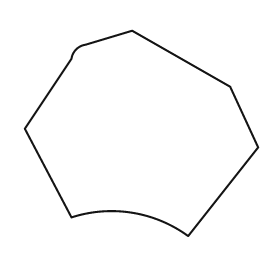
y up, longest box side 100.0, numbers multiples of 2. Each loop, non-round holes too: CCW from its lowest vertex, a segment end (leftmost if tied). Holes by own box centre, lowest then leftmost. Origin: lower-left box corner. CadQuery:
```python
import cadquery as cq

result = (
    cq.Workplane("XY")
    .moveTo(70.0, 0.0)
    .lineTo(100.0, 38.0)
    .lineTo(88.0, 64.0)
    .lineTo(46.0, 88.0)
    .lineTo(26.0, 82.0)
    .threePointArc((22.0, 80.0), (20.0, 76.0))
    .lineTo(0.0, 46.0)
    .lineTo(20.0, 8.0)
    .threePointArc((46.0, 10.0), (70.0, 0.0))
    .close()
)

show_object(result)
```